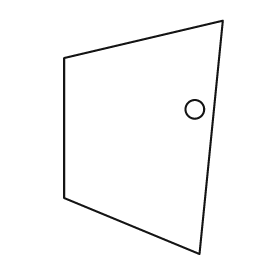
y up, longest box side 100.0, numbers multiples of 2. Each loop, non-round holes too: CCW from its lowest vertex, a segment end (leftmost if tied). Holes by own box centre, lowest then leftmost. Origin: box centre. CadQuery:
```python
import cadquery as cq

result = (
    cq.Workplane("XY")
    .moveTo(24.0, -50.0)
    .lineTo(34.0, 50.0)
    .lineTo(-34.0, 34.0)
    .lineTo(-34.0, -26.0)
    .close()
    .moveTo(22.0, 12.0)
    .circle(4.0)
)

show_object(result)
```